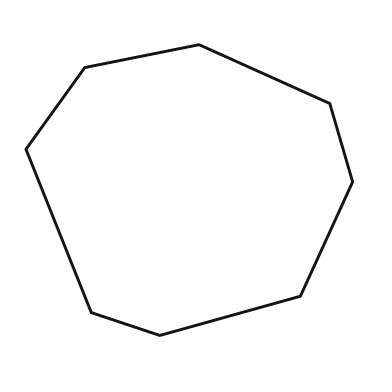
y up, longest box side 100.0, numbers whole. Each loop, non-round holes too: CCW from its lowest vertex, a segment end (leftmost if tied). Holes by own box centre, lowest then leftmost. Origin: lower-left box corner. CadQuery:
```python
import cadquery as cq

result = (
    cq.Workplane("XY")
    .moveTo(41.0, 0.0)
    .lineTo(84.0, 12.0)
    .lineTo(100.0, 47.0)
    .lineTo(93.0, 71.0)
    .lineTo(53.0, 89.0)
    .lineTo(18.0, 82.0)
    .lineTo(0.0, 57.0)
    .lineTo(20.0, 7.0)
    .close()
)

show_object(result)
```